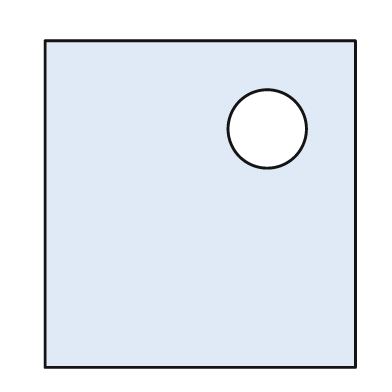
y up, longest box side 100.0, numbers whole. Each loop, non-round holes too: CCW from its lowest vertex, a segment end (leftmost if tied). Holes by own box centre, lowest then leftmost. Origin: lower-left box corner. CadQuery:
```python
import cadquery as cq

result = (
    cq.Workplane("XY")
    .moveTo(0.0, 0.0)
    .lineTo(95.0, 0.0)
    .lineTo(95.0, 100.0)
    .lineTo(0.0, 100.0)
    .close()
    .moveTo(68.0, 73.0)
    .circle(12.0)
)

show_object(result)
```